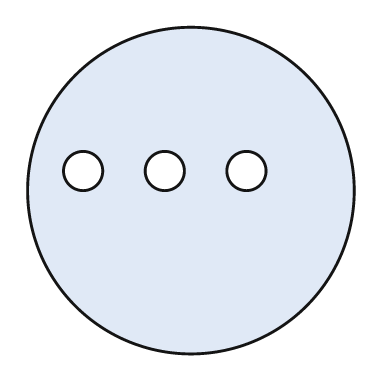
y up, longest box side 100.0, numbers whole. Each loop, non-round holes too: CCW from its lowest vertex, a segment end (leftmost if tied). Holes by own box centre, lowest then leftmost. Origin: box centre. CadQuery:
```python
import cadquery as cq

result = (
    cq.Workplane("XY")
    .moveTo(0.0, 0.0)
    .circle(50.0)
    .moveTo(-33.0, 6.0)
    .circle(6.0)
    .moveTo(-8.0, 6.0)
    .circle(6.0)
    .moveTo(17.0, 6.0)
    .circle(6.0)
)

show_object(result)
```